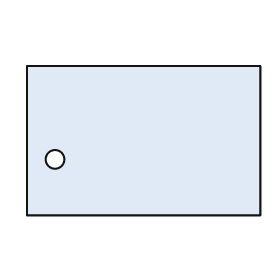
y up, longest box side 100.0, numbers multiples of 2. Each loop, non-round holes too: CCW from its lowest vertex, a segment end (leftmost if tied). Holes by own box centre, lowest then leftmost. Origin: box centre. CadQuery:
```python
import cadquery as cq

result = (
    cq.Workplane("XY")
    .moveTo(-50.0, -32.0)
    .lineTo(50.0, -32.0)
    .lineTo(50.0, 32.0)
    .lineTo(-50.0, 32.0)
    .close()
    .moveTo(-38.0, -8.0)
    .circle(4.0)
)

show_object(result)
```